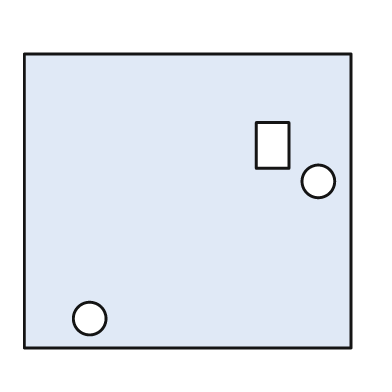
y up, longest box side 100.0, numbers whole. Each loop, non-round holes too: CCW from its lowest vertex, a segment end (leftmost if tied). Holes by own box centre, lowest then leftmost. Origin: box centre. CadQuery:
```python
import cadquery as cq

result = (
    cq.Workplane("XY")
    .moveTo(-50.0, -45.0)
    .lineTo(50.0, -45.0)
    .lineTo(50.0, 45.0)
    .lineTo(-50.0, 45.0)
    .close()
    .moveTo(-30.0, -36.0)
    .circle(5.0)
    .moveTo(40.0, 6.0)
    .circle(5.0)
    .moveTo(21.0, 10.0)
    .lineTo(31.0, 10.0)
    .lineTo(31.0, 24.0)
    .lineTo(21.0, 24.0)
    .close()
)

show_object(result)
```